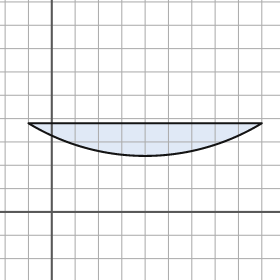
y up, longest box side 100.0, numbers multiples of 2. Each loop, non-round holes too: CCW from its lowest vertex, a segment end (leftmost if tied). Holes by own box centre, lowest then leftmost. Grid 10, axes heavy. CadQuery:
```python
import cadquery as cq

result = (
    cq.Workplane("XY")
    .moveTo(-10.0, 38.0)
    .threePointArc((40.0, 24.0), (90.0, 38.0))
    .close()
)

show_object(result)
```